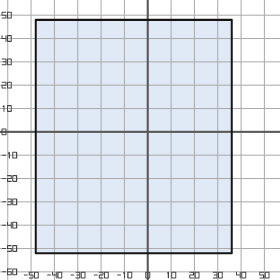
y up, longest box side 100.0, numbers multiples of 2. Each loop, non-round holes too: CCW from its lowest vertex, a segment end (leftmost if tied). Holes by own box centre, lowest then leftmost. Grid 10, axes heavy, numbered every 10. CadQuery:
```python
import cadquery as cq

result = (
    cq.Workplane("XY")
    .moveTo(-48.0, -52.0)
    .lineTo(36.0, -52.0)
    .lineTo(36.0, 48.0)
    .lineTo(-48.0, 48.0)
    .close()
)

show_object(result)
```